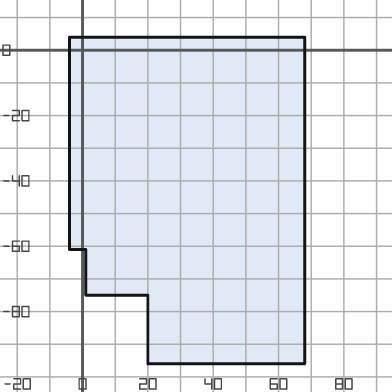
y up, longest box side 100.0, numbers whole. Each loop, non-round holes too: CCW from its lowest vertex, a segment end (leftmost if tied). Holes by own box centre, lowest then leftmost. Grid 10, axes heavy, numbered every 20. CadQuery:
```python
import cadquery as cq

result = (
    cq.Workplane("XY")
    .moveTo(20.0, -96.0)
    .lineTo(68.0, -96.0)
    .lineTo(68.0, 4.0)
    .lineTo(-4.0, 4.0)
    .lineTo(-4.0, -61.0)
    .lineTo(1.0, -61.0)
    .lineTo(1.0, -75.0)
    .lineTo(20.0, -75.0)
    .close()
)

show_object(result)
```